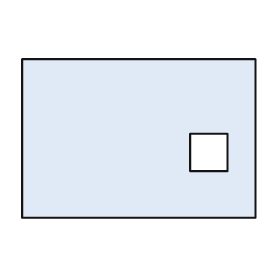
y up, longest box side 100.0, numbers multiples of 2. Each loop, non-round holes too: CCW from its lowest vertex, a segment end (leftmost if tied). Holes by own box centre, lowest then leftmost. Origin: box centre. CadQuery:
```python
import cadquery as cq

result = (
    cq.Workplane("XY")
    .moveTo(-50.0, -34.0)
    .lineTo(50.0, -34.0)
    .lineTo(50.0, 34.0)
    .lineTo(-50.0, 34.0)
    .close()
    .moveTo(22.0, -14.0)
    .lineTo(38.0, -14.0)
    .lineTo(38.0, 2.0)
    .lineTo(22.0, 2.0)
    .close()
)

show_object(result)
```